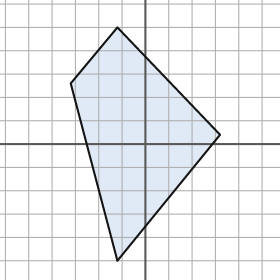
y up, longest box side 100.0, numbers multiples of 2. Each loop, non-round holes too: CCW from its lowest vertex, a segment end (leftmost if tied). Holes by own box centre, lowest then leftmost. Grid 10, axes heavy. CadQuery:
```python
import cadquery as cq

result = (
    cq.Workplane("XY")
    .moveTo(-12.0, -50.0)
    .lineTo(32.0, 4.0)
    .lineTo(-12.0, 50.0)
    .lineTo(-32.0, 26.0)
    .close()
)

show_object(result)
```